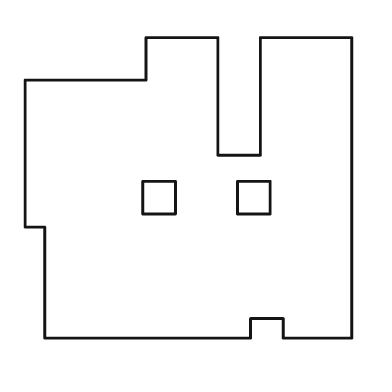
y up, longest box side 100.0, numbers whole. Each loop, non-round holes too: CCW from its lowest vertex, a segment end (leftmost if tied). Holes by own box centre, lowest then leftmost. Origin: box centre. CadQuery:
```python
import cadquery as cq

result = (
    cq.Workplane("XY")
    .moveTo(-44.0, -46.0)
    .lineTo(19.0, -46.0)
    .lineTo(19.0, -40.0)
    .lineTo(29.0, -40.0)
    .lineTo(29.0, -46.0)
    .lineTo(50.0, -46.0)
    .lineTo(50.0, 46.0)
    .lineTo(22.0, 46.0)
    .lineTo(22.0, 10.0)
    .lineTo(9.0, 10.0)
    .lineTo(9.0, 46.0)
    .lineTo(-13.0, 46.0)
    .lineTo(-13.0, 33.0)
    .lineTo(-50.0, 33.0)
    .lineTo(-50.0, -12.0)
    .lineTo(-44.0, -12.0)
    .close()
    .moveTo(-14.0, -8.0)
    .lineTo(-4.0, -8.0)
    .lineTo(-4.0, 2.0)
    .lineTo(-14.0, 2.0)
    .close()
    .moveTo(15.0, -8.0)
    .lineTo(25.0, -8.0)
    .lineTo(25.0, 2.0)
    .lineTo(15.0, 2.0)
    .close()
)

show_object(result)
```